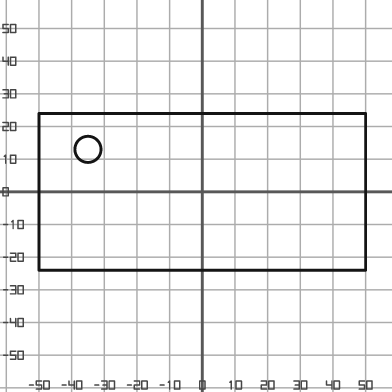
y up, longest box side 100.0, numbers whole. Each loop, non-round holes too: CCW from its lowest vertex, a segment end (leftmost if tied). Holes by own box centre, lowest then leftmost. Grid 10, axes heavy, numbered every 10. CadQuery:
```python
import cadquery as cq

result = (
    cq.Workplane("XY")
    .moveTo(-50.0, -24.0)
    .lineTo(50.0, -24.0)
    .lineTo(50.0, 24.0)
    .lineTo(-50.0, 24.0)
    .close()
    .moveTo(-35.0, 13.0)
    .circle(4.0)
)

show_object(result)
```